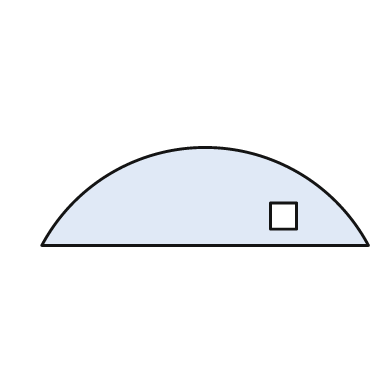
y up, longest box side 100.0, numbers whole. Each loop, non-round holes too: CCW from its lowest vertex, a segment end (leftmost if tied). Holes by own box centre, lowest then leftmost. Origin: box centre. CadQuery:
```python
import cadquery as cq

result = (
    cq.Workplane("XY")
    .moveTo(-50.0, -15.0)
    .lineTo(50.0, -15.0)
    .threePointArc((0.0, 15.0), (-50.0, -15.0))
    .close()
    .moveTo(20.0, -10.0)
    .lineTo(28.0, -10.0)
    .lineTo(28.0, -2.0)
    .lineTo(20.0, -2.0)
    .close()
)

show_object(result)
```